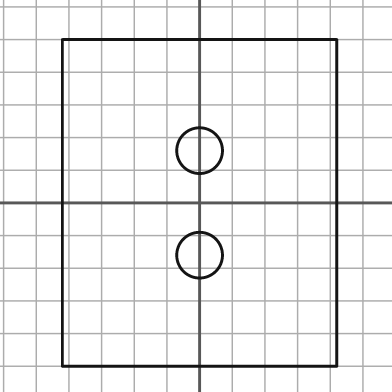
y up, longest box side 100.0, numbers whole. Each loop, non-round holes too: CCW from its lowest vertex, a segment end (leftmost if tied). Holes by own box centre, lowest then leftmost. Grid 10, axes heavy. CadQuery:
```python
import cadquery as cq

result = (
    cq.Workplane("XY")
    .moveTo(-42.0, -50.0)
    .lineTo(42.0, -50.0)
    .lineTo(42.0, 50.0)
    .lineTo(-42.0, 50.0)
    .close()
    .moveTo(0.0, -16.0)
    .circle(7.0)
    .moveTo(0.0, 16.0)
    .circle(7.0)
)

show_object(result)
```